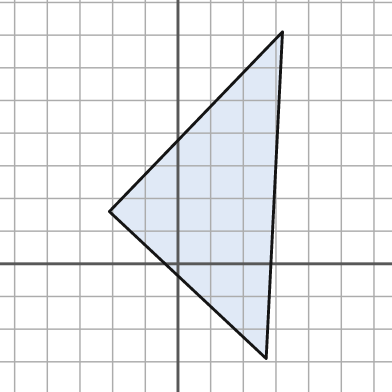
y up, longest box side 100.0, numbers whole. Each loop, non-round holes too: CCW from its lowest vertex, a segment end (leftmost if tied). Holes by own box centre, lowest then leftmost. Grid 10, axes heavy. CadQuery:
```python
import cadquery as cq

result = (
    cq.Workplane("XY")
    .moveTo(27.0, -29.0)
    .lineTo(32.0, 71.0)
    .lineTo(-21.0, 16.0)
    .close()
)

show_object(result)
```